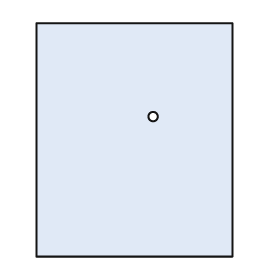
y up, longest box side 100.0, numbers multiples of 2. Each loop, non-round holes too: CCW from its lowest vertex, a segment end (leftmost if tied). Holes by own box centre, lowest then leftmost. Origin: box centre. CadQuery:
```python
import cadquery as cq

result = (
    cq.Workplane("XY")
    .moveTo(-42.0, -50.0)
    .lineTo(42.0, -50.0)
    .lineTo(42.0, 50.0)
    .lineTo(-42.0, 50.0)
    .close()
    .moveTo(8.0, 10.0)
    .circle(2.0)
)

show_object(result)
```